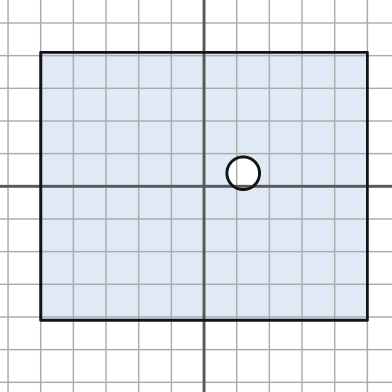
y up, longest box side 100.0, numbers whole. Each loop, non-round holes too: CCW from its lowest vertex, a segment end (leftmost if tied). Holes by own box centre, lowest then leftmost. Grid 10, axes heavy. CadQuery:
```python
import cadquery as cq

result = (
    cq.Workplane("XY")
    .moveTo(-50.0, -41.0)
    .lineTo(50.0, -41.0)
    .lineTo(50.0, 41.0)
    .lineTo(-50.0, 41.0)
    .close()
    .moveTo(12.0, 4.0)
    .circle(5.0)
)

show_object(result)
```